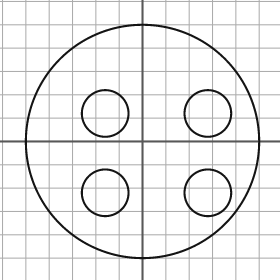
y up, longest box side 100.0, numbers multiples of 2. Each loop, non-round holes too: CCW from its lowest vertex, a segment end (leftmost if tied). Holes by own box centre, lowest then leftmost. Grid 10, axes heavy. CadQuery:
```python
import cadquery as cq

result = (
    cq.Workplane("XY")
    .moveTo(0.0, 0.0)
    .circle(50.0)
    .moveTo(-16.0, -22.0)
    .circle(10.0)
    .moveTo(28.0, -22.0)
    .circle(10.0)
    .moveTo(-16.0, 12.0)
    .circle(10.0)
    .moveTo(28.0, 12.0)
    .circle(10.0)
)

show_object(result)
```